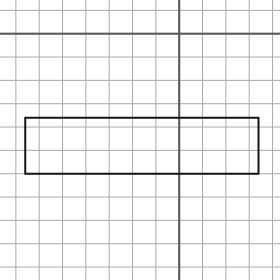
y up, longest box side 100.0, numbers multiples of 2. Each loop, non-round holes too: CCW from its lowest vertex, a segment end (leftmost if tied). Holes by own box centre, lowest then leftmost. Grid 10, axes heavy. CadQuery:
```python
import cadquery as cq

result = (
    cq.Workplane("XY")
    .moveTo(-66.0, -60.0)
    .lineTo(34.0, -60.0)
    .lineTo(34.0, -36.0)
    .lineTo(-66.0, -36.0)
    .close()
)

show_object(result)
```